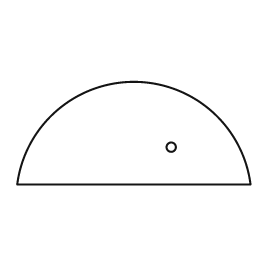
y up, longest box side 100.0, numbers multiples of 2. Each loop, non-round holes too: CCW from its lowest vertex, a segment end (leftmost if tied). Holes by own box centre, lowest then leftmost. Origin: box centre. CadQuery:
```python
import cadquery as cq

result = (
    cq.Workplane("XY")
    .moveTo(-50.0, -22.0)
    .lineTo(50.0, -22.0)
    .threePointArc((0.0, 22.0), (-50.0, -22.0))
    .close()
    .moveTo(16.0, -6.0)
    .circle(2.0)
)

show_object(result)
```